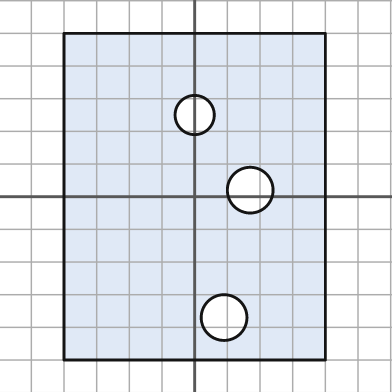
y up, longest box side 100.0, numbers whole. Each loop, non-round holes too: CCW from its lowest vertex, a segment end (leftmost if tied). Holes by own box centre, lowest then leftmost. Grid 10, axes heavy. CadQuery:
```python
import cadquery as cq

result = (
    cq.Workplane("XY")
    .moveTo(-40.0, -50.0)
    .lineTo(40.0, -50.0)
    .lineTo(40.0, 50.0)
    .lineTo(-40.0, 50.0)
    .close()
    .moveTo(9.0, -37.0)
    .circle(7.0)
    .moveTo(17.0, 2.0)
    .circle(7.0)
    .moveTo(0.0, 25.0)
    .circle(6.0)
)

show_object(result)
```